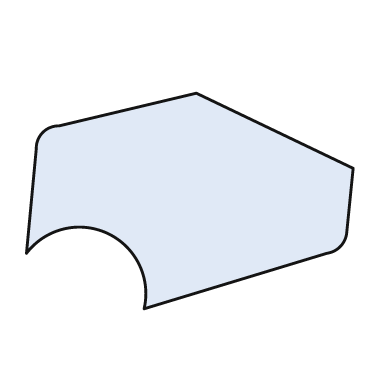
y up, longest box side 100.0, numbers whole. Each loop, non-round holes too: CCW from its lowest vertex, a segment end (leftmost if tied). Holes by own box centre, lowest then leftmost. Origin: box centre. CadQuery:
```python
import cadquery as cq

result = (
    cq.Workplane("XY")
    .moveTo(-14.0, -33.0)
    .lineTo(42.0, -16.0)
    .threePointArc((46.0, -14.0), (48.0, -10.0))
    .lineTo(50.0, 10.0)
    .lineTo(2.0, 33.0)
    .lineTo(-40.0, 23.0)
    .threePointArc((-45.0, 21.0), (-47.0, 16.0))
    .lineTo(-50.0, -16.0)
    .threePointArc((-25.0, -10.0), (-14.0, -33.0))
    .close()
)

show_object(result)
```